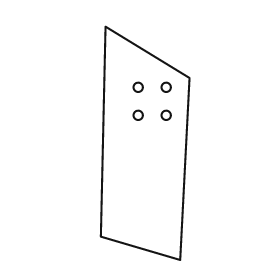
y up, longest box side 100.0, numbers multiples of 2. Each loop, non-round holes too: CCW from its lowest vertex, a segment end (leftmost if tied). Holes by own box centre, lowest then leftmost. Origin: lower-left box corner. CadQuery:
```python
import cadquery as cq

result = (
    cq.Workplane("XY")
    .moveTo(34.0, 0.0)
    .lineTo(38.0, 78.0)
    .lineTo(2.0, 100.0)
    .lineTo(0.0, 10.0)
    .close()
    .moveTo(16.0, 62.0)
    .circle(2.0)
    .moveTo(28.0, 62.0)
    .circle(2.0)
    .moveTo(16.0, 74.0)
    .circle(2.0)
    .moveTo(28.0, 74.0)
    .circle(2.0)
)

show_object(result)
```